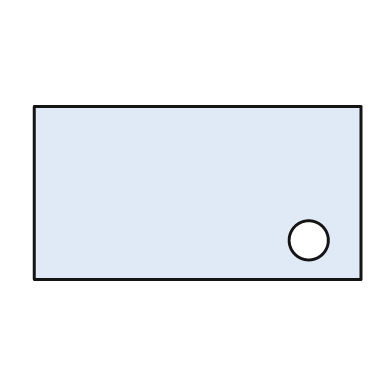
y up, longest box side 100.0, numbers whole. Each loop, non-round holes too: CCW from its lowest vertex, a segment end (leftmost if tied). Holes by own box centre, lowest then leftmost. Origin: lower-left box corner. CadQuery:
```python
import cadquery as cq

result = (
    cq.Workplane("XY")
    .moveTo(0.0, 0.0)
    .lineTo(100.0, 0.0)
    .lineTo(100.0, 53.0)
    .lineTo(0.0, 53.0)
    .close()
    .moveTo(84.0, 12.0)
    .circle(6.0)
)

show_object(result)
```